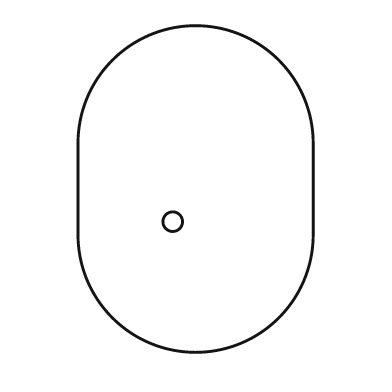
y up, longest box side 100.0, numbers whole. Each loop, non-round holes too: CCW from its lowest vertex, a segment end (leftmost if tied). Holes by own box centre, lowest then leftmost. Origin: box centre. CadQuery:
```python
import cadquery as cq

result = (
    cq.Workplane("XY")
    .moveTo(-36.0, -14.0)
    .threePointArc((0.0, -50.0), (36.0, -14.0))
    .lineTo(36.0, 14.0)
    .threePointArc((0.0, 50.0), (-36.0, 14.0))
    .close()
    .moveTo(-7.0, -10.0)
    .circle(3.0)
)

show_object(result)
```